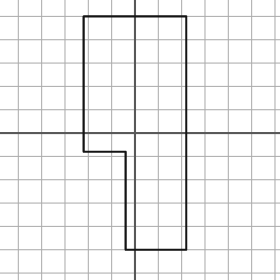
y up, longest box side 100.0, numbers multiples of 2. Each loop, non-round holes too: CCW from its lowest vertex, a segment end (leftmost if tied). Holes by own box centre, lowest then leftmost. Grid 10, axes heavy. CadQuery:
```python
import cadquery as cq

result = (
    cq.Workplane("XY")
    .moveTo(-4.0, -50.0)
    .lineTo(22.0, -50.0)
    .lineTo(22.0, 50.0)
    .lineTo(-22.0, 50.0)
    .lineTo(-22.0, -8.0)
    .lineTo(-4.0, -8.0)
    .close()
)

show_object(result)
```